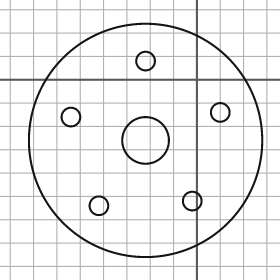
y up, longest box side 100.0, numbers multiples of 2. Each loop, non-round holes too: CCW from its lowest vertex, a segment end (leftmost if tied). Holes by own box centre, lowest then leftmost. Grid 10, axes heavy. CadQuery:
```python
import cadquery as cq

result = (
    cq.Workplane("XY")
    .moveTo(-22.0, -26.0)
    .circle(50.0)
    .moveTo(-42.0, -54.0)
    .circle(4.0)
    .moveTo(-2.0, -52.0)
    .circle(4.0)
    .moveTo(-22.0, -26.0)
    .circle(10.0)
    .moveTo(-54.0, -16.0)
    .circle(4.0)
    .moveTo(10.0, -14.0)
    .circle(4.0)
    .moveTo(-22.0, 8.0)
    .circle(4.0)
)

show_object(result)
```